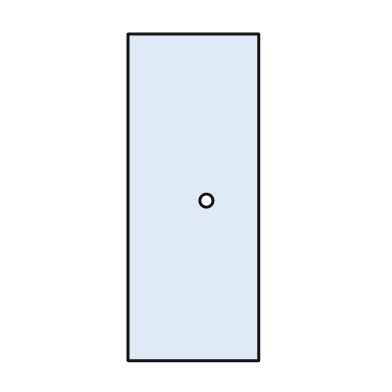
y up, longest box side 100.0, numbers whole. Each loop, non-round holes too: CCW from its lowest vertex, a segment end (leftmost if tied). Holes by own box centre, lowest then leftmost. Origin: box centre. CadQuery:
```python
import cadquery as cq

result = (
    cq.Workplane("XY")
    .moveTo(-20.0, -50.0)
    .lineTo(20.0, -50.0)
    .lineTo(20.0, 50.0)
    .lineTo(-20.0, 50.0)
    .close()
    .moveTo(4.0, -1.0)
    .circle(2.0)
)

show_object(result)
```